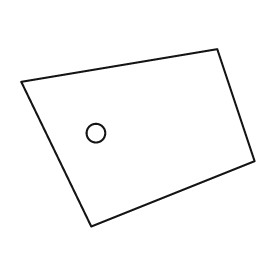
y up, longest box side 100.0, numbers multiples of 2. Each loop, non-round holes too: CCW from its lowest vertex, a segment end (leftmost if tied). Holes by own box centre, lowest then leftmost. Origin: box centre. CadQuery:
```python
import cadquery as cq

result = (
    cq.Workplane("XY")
    .moveTo(-20.0, -38.0)
    .lineTo(50.0, -10.0)
    .lineTo(34.0, 38.0)
    .lineTo(-50.0, 24.0)
    .close()
    .moveTo(-18.0, 2.0)
    .circle(4.0)
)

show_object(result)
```